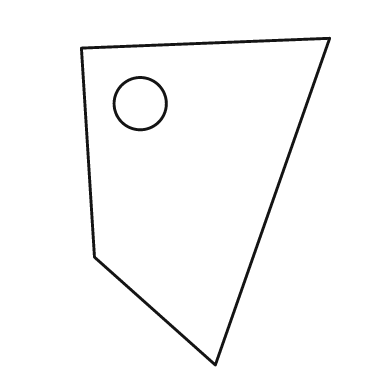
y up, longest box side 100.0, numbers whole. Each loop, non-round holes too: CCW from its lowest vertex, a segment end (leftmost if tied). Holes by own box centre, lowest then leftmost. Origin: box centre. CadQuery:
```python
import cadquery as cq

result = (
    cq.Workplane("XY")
    .moveTo(3.0, -50.0)
    .lineTo(38.0, 50.0)
    .lineTo(-38.0, 47.0)
    .lineTo(-34.0, -17.0)
    .close()
    .moveTo(-20.0, 30.0)
    .circle(8.0)
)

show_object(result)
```